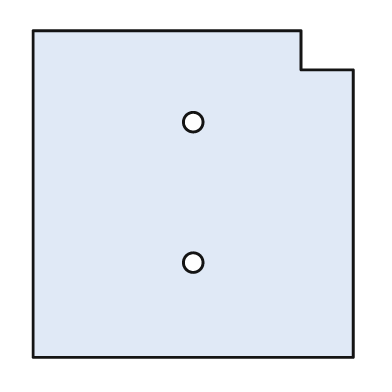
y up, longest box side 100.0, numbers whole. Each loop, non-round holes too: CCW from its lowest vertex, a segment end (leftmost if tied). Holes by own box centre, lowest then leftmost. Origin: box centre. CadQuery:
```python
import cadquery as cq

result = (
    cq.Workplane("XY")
    .moveTo(-49.0, -50.0)
    .lineTo(49.0, -50.0)
    .lineTo(49.0, 38.0)
    .lineTo(33.0, 38.0)
    .lineTo(33.0, 50.0)
    .lineTo(-49.0, 50.0)
    .close()
    .moveTo(0.0, -21.0)
    .circle(3.0)
    .moveTo(0.0, 22.0)
    .circle(3.0)
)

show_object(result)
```